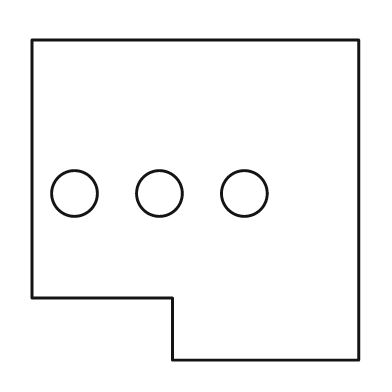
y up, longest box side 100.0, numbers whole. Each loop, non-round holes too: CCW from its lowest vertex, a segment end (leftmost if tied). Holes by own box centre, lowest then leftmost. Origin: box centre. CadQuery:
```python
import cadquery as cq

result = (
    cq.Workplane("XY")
    .moveTo(-7.0, -49.0)
    .lineTo(50.0, -49.0)
    .lineTo(50.0, 49.0)
    .lineTo(-50.0, 49.0)
    .lineTo(-50.0, -30.0)
    .lineTo(-7.0, -30.0)
    .close()
    .moveTo(-37.0, 2.0)
    .circle(7.0)
    .moveTo(-11.0, 2.0)
    .circle(7.0)
    .moveTo(15.0, 2.0)
    .circle(7.0)
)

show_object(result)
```